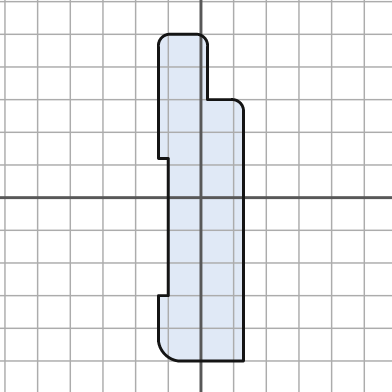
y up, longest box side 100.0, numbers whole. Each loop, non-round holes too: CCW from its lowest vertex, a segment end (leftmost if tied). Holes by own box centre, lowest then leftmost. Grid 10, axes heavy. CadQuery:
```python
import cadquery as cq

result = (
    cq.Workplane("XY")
    .moveTo(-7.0, -50.0)
    .lineTo(13.0, -50.0)
    .lineTo(13.0, 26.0)
    .threePointArc((12.0, 29.0), (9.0, 30.0))
    .lineTo(2.0, 30.0)
    .lineTo(2.0, 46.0)
    .threePointArc((1.0, 49.0), (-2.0, 50.0))
    .lineTo(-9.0, 50.0)
    .threePointArc((-12.0, 49.0), (-13.0, 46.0))
    .lineTo(-13.0, 12.0)
    .lineTo(-10.0, 12.0)
    .lineTo(-10.0, -30.0)
    .lineTo(-13.0, -30.0)
    .lineTo(-13.0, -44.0)
    .threePointArc((-11.0, -48.0), (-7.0, -50.0))
    .close()
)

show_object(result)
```